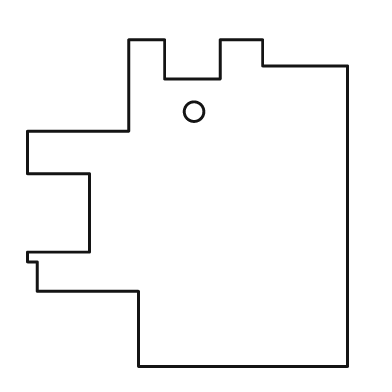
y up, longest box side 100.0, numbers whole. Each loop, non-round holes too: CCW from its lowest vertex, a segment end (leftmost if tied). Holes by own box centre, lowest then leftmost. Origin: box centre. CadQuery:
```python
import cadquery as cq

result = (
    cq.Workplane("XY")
    .moveTo(-15.0, -50.0)
    .lineTo(49.0, -50.0)
    .lineTo(49.0, 42.0)
    .lineTo(23.0, 42.0)
    .lineTo(23.0, 50.0)
    .lineTo(10.0, 50.0)
    .lineTo(10.0, 38.0)
    .lineTo(-7.0, 38.0)
    .lineTo(-7.0, 50.0)
    .lineTo(-18.0, 50.0)
    .lineTo(-18.0, 22.0)
    .lineTo(-49.0, 22.0)
    .lineTo(-49.0, 9.0)
    .lineTo(-30.0, 9.0)
    .lineTo(-30.0, -15.0)
    .lineTo(-49.0, -15.0)
    .lineTo(-49.0, -18.0)
    .lineTo(-46.0, -18.0)
    .lineTo(-46.0, -27.0)
    .lineTo(-15.0, -27.0)
    .close()
    .moveTo(2.0, 28.0)
    .circle(3.0)
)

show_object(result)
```